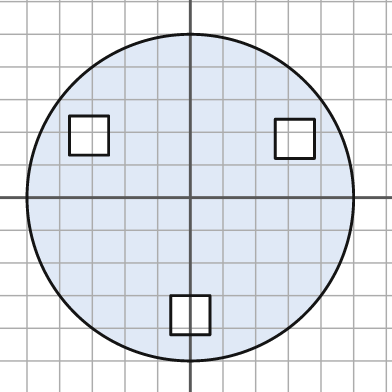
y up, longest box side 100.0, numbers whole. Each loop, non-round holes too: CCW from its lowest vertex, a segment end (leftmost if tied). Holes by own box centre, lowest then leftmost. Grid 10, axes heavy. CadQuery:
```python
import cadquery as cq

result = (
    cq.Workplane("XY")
    .moveTo(0.0, 0.0)
    .circle(50.0)
    .moveTo(-6.0, -42.0)
    .lineTo(6.0, -42.0)
    .lineTo(6.0, -30.0)
    .lineTo(-6.0, -30.0)
    .close()
    .moveTo(26.0, 12.0)
    .lineTo(38.0, 12.0)
    .lineTo(38.0, 24.0)
    .lineTo(26.0, 24.0)
    .close()
    .moveTo(-37.0, 13.0)
    .lineTo(-25.0, 13.0)
    .lineTo(-25.0, 25.0)
    .lineTo(-37.0, 25.0)
    .close()
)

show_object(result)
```